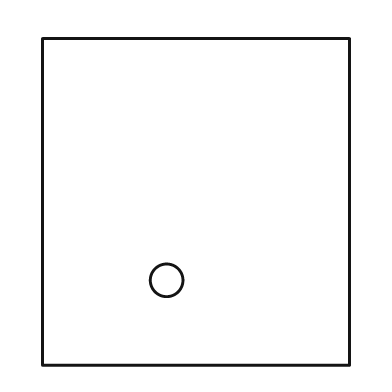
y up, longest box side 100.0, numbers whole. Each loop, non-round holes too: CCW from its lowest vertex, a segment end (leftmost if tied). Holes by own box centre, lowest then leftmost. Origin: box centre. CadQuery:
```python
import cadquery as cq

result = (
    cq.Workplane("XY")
    .moveTo(-47.0, -50.0)
    .lineTo(47.0, -50.0)
    .lineTo(47.0, 50.0)
    .lineTo(-47.0, 50.0)
    .close()
    .moveTo(-9.0, -24.0)
    .circle(5.0)
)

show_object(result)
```